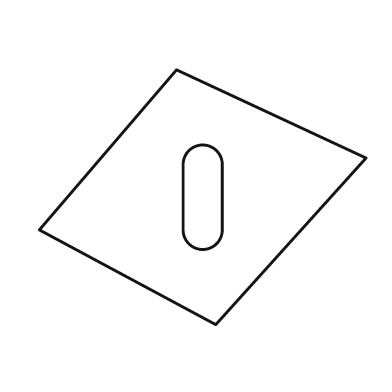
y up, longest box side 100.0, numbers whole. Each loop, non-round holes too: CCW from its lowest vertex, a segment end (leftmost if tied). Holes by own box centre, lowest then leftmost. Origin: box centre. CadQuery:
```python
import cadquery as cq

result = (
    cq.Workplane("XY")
    .moveTo(4.0, -39.0)
    .lineTo(50.0, 12.0)
    .lineTo(-8.0, 39.0)
    .lineTo(-50.0, -10.0)
    .close()
    .moveTo(-6.0, -10.0)
    .threePointArc((0.0, -16.0), (6.0, -10.0))
    .lineTo(6.0, 10.0)
    .threePointArc((0.0, 16.0), (-6.0, 10.0))
    .close()
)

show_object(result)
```